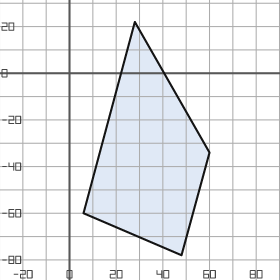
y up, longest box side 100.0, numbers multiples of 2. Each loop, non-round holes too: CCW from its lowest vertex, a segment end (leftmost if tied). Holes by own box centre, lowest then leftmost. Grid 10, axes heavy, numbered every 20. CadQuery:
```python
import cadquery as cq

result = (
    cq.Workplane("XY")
    .moveTo(48.0, -78.0)
    .lineTo(60.0, -34.0)
    .lineTo(28.0, 22.0)
    .lineTo(6.0, -60.0)
    .close()
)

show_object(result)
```